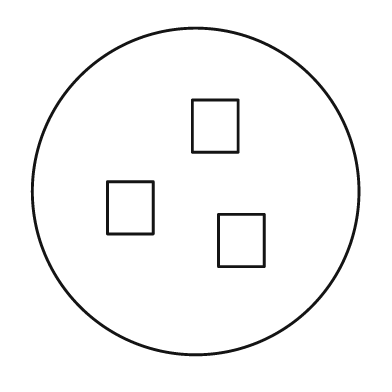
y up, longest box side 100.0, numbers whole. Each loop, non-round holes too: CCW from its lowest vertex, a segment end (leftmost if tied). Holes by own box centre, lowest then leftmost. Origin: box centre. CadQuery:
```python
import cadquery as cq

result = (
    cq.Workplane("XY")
    .moveTo(0.0, 0.0)
    .circle(50.0)
    .moveTo(7.0, -23.0)
    .lineTo(21.0, -23.0)
    .lineTo(21.0, -7.0)
    .lineTo(7.0, -7.0)
    .close()
    .moveTo(-27.0, -13.0)
    .lineTo(-13.0, -13.0)
    .lineTo(-13.0, 3.0)
    .lineTo(-27.0, 3.0)
    .close()
    .moveTo(-1.0, 12.0)
    .lineTo(13.0, 12.0)
    .lineTo(13.0, 28.0)
    .lineTo(-1.0, 28.0)
    .close()
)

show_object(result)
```